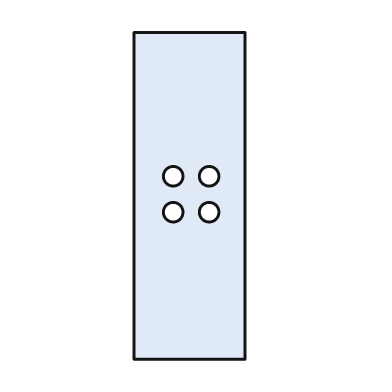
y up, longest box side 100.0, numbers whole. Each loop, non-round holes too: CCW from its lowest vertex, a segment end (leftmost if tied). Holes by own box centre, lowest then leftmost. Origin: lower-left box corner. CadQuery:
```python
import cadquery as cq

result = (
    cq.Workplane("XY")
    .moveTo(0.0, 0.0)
    .lineTo(34.0, 0.0)
    .lineTo(34.0, 100.0)
    .lineTo(0.0, 100.0)
    .close()
    .moveTo(12.0, 45.0)
    .circle(3.0)
    .moveTo(23.0, 45.0)
    .circle(3.0)
    .moveTo(12.0, 56.0)
    .circle(3.0)
    .moveTo(23.0, 56.0)
    .circle(3.0)
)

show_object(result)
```